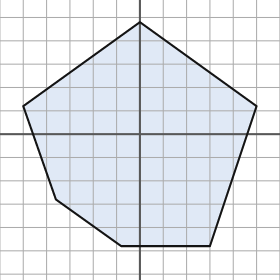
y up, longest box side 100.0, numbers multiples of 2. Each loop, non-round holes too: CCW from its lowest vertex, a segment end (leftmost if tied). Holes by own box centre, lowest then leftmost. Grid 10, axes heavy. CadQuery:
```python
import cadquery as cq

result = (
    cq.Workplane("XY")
    .moveTo(-8.0, -48.0)
    .lineTo(30.0, -48.0)
    .lineTo(50.0, 12.0)
    .lineTo(0.0, 48.0)
    .lineTo(-50.0, 12.0)
    .lineTo(-36.0, -28.0)
    .close()
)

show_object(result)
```